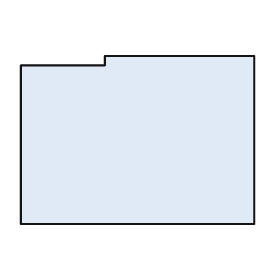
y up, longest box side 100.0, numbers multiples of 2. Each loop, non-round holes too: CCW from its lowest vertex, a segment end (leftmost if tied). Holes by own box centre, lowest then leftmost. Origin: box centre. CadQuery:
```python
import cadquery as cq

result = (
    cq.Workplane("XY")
    .moveTo(-50.0, -36.0)
    .lineTo(50.0, -36.0)
    .lineTo(50.0, 36.0)
    .lineTo(-14.0, 36.0)
    .lineTo(-14.0, 32.0)
    .lineTo(-50.0, 32.0)
    .close()
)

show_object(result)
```